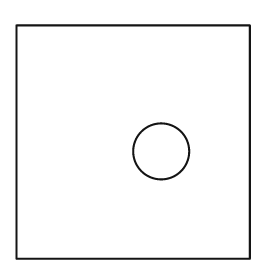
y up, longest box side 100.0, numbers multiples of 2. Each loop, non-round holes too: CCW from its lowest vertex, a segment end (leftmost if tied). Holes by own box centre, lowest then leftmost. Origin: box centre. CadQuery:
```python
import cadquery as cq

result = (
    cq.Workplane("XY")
    .moveTo(-50.0, -50.0)
    .lineTo(50.0, -50.0)
    .lineTo(50.0, 50.0)
    .lineTo(-50.0, 50.0)
    .close()
    .moveTo(12.0, -4.0)
    .circle(12.0)
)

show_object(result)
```